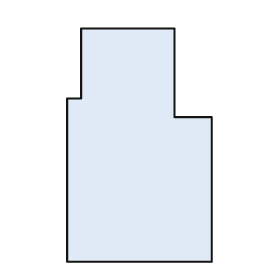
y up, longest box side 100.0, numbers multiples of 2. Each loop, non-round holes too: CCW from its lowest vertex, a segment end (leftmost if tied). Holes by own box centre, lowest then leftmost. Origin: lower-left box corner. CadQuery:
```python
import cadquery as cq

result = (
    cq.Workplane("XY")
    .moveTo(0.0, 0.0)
    .lineTo(62.0, 0.0)
    .lineTo(62.0, 62.0)
    .lineTo(46.0, 62.0)
    .lineTo(46.0, 100.0)
    .lineTo(6.0, 100.0)
    .lineTo(6.0, 70.0)
    .lineTo(0.0, 70.0)
    .close()
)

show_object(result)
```